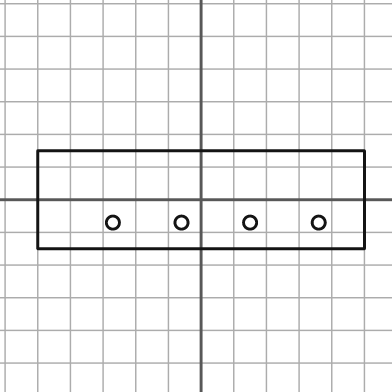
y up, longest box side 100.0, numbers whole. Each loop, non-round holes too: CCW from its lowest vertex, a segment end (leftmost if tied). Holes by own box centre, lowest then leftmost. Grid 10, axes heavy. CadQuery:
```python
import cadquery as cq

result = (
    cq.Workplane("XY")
    .moveTo(-50.0, -15.0)
    .lineTo(50.0, -15.0)
    .lineTo(50.0, 15.0)
    .lineTo(-50.0, 15.0)
    .close()
    .moveTo(-27.0, -7.0)
    .circle(2.0)
    .moveTo(-6.0, -7.0)
    .circle(2.0)
    .moveTo(15.0, -7.0)
    .circle(2.0)
    .moveTo(36.0, -7.0)
    .circle(2.0)
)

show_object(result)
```